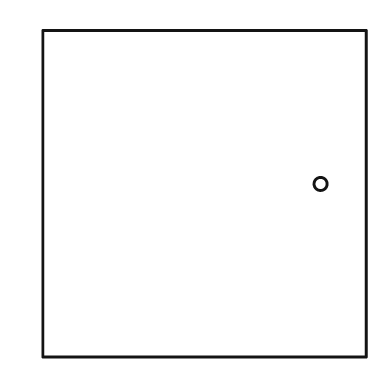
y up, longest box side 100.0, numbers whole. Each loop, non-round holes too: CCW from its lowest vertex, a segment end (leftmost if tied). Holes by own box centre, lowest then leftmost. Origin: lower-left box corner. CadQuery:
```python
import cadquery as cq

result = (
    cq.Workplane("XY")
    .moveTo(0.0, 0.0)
    .lineTo(99.0, 0.0)
    .lineTo(99.0, 100.0)
    .lineTo(0.0, 100.0)
    .close()
    .moveTo(85.0, 53.0)
    .circle(2.0)
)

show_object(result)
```